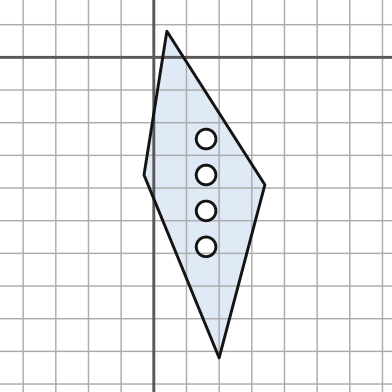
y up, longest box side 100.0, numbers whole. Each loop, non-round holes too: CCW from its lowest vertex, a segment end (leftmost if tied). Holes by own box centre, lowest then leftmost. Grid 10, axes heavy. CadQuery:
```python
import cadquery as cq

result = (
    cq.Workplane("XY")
    .moveTo(20.0, -92.0)
    .lineTo(34.0, -39.0)
    .lineTo(4.0, 8.0)
    .lineTo(-3.0, -36.0)
    .close()
    .moveTo(16.0, -58.0)
    .circle(3.0)
    .moveTo(16.0, -47.0)
    .circle(3.0)
    .moveTo(16.0, -36.0)
    .circle(3.0)
    .moveTo(16.0, -25.0)
    .circle(3.0)
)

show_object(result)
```